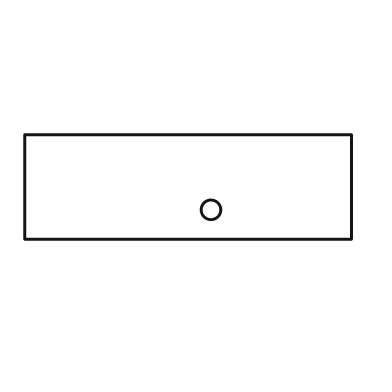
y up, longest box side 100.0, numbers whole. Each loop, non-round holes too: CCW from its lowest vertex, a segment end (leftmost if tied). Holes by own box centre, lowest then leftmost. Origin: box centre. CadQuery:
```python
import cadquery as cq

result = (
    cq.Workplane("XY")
    .moveTo(-50.0, -16.0)
    .lineTo(50.0, -16.0)
    .lineTo(50.0, 16.0)
    .lineTo(-50.0, 16.0)
    .close()
    .moveTo(7.0, -7.0)
    .circle(3.0)
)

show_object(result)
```